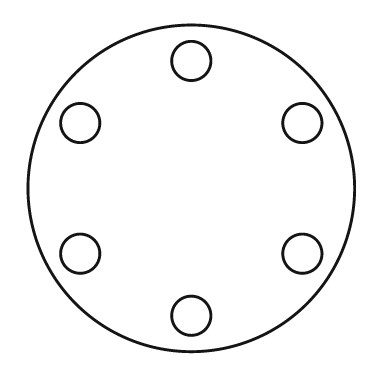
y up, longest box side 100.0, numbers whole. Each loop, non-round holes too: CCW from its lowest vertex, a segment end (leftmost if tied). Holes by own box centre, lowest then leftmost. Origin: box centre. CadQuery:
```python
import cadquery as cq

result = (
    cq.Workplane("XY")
    .moveTo(0.0, 0.0)
    .circle(50.0)
    .moveTo(0.0, -39.0)
    .circle(6.0)
    .moveTo(-34.0, -20.0)
    .circle(6.0)
    .moveTo(34.0, -20.0)
    .circle(6.0)
    .moveTo(-34.0, 20.0)
    .circle(6.0)
    .moveTo(34.0, 20.0)
    .circle(6.0)
    .moveTo(0.0, 39.0)
    .circle(6.0)
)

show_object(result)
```